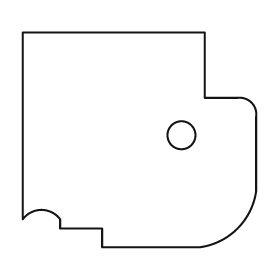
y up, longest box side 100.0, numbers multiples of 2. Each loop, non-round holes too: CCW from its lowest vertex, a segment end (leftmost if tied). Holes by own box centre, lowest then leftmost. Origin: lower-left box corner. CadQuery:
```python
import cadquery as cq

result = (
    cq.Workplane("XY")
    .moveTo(34.0, 0.0)
    .lineTo(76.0, 0.0)
    .threePointArc((92.0, 8.0), (100.0, 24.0))
    .lineTo(100.0, 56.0)
    .threePointArc((98.0, 62.0), (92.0, 64.0))
    .lineTo(78.0, 64.0)
    .lineTo(78.0, 92.0)
    .lineTo(0.0, 92.0)
    .lineTo(0.0, 12.0)
    .threePointArc((8.0, 16.0), (16.0, 12.0))
    .lineTo(16.0, 8.0)
    .lineTo(34.0, 8.0)
    .close()
    .moveTo(68.0, 48.0)
    .circle(6.0)
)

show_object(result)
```